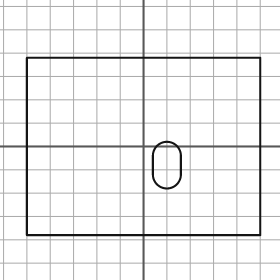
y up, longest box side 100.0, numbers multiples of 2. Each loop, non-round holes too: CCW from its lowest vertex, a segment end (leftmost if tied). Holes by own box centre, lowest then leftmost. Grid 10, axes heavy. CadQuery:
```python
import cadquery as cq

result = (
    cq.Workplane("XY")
    .moveTo(-50.0, -38.0)
    .lineTo(50.0, -38.0)
    .lineTo(50.0, 38.0)
    .lineTo(-50.0, 38.0)
    .close()
    .moveTo(4.0, -12.0)
    .threePointArc((10.0, -18.0), (16.0, -12.0))
    .lineTo(16.0, -4.0)
    .threePointArc((10.0, 2.0), (4.0, -4.0))
    .close()
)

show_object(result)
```